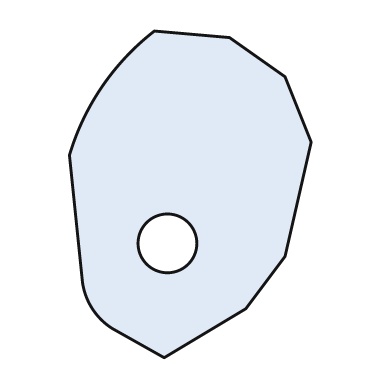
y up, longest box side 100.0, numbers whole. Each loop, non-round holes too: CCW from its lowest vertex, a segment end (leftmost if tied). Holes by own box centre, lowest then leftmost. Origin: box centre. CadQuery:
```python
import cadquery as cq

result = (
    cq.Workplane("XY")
    .moveTo(-8.0, -50.0)
    .lineTo(17.0, -35.0)
    .lineTo(29.0, -19.0)
    .lineTo(37.0, 16.0)
    .lineTo(29.0, 36.0)
    .lineTo(12.0, 48.0)
    .lineTo(-11.0, 50.0)
    .threePointArc((-27.0, 33.0), (-37.0, 12.0))
    .lineTo(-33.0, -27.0)
    .threePointArc((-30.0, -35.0), (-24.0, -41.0))
    .close()
    .moveTo(-7.0, -15.0)
    .circle(9.0)
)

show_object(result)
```